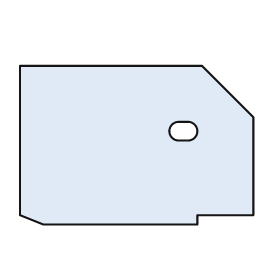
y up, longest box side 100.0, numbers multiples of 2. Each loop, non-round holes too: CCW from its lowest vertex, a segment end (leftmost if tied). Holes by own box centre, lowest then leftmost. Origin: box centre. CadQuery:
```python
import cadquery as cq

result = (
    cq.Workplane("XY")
    .moveTo(-40.0, -34.0)
    .lineTo(26.0, -34.0)
    .lineTo(26.0, -30.0)
    .lineTo(50.0, -30.0)
    .lineTo(50.0, 12.0)
    .lineTo(28.0, 34.0)
    .lineTo(-50.0, 34.0)
    .lineTo(-50.0, -30.0)
    .close()
    .moveTo(18.0, 2.0)
    .lineTo(22.0, 2.0)
    .threePointArc((26.0, 6.0), (22.0, 10.0))
    .lineTo(18.0, 10.0)
    .threePointArc((14.0, 6.0), (18.0, 2.0))
    .close()
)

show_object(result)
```